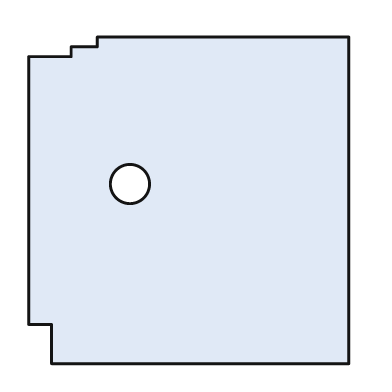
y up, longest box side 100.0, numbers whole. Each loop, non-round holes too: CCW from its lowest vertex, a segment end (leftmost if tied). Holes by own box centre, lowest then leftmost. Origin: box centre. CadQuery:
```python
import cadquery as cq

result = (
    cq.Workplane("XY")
    .moveTo(-42.0, -50.0)
    .lineTo(49.0, -50.0)
    .lineTo(49.0, 50.0)
    .lineTo(-28.0, 50.0)
    .lineTo(-28.0, 47.0)
    .lineTo(-36.0, 47.0)
    .lineTo(-36.0, 44.0)
    .lineTo(-49.0, 44.0)
    .lineTo(-49.0, -38.0)
    .lineTo(-42.0, -38.0)
    .close()
    .moveTo(-18.0, 5.0)
    .circle(6.0)
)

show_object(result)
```